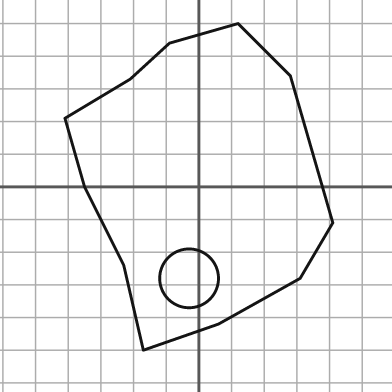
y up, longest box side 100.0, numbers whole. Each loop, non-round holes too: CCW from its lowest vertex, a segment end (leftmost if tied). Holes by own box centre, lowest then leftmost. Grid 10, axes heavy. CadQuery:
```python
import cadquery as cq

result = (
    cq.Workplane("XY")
    .moveTo(-17.0, -50.0)
    .lineTo(6.0, -42.0)
    .lineTo(31.0, -28.0)
    .lineTo(41.0, -11.0)
    .lineTo(28.0, 34.0)
    .lineTo(12.0, 50.0)
    .lineTo(-9.0, 44.0)
    .lineTo(-21.0, 33.0)
    .lineTo(-41.0, 21.0)
    .lineTo(-35.0, 0.0)
    .lineTo(-23.0, -24.0)
    .close()
    .moveTo(-3.0, -28.0)
    .circle(9.0)
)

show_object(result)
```